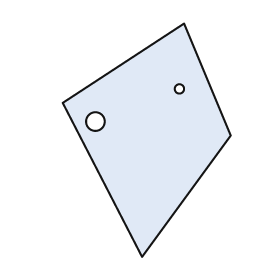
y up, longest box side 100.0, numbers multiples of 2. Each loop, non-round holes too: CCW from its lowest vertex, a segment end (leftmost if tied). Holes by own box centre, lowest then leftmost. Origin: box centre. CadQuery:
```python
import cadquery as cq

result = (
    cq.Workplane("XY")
    .moveTo(-2.0, -50.0)
    .lineTo(36.0, 2.0)
    .lineTo(16.0, 50.0)
    .lineTo(-36.0, 16.0)
    .close()
    .moveTo(-22.0, 8.0)
    .circle(4.0)
    .moveTo(14.0, 22.0)
    .circle(2.0)
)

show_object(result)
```